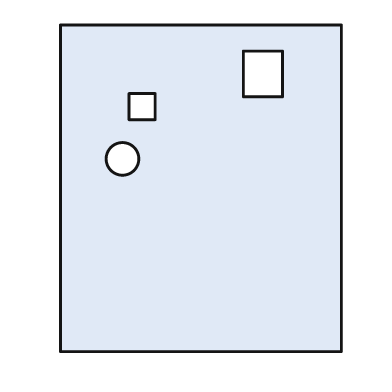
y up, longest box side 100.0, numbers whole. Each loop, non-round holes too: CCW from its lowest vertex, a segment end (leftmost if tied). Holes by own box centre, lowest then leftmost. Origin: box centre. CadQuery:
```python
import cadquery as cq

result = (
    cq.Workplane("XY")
    .moveTo(-43.0, -50.0)
    .lineTo(43.0, -50.0)
    .lineTo(43.0, 50.0)
    .lineTo(-43.0, 50.0)
    .close()
    .moveTo(-24.0, 9.0)
    .circle(5.0)
    .moveTo(-22.0, 21.0)
    .lineTo(-14.0, 21.0)
    .lineTo(-14.0, 29.0)
    .lineTo(-22.0, 29.0)
    .close()
    .moveTo(13.0, 28.0)
    .lineTo(25.0, 28.0)
    .lineTo(25.0, 42.0)
    .lineTo(13.0, 42.0)
    .close()
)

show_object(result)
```